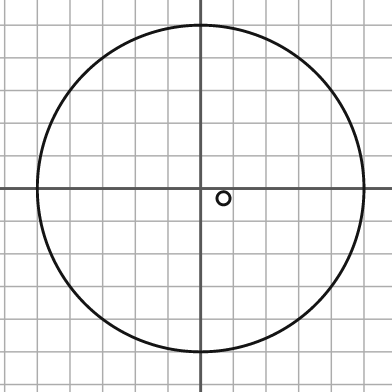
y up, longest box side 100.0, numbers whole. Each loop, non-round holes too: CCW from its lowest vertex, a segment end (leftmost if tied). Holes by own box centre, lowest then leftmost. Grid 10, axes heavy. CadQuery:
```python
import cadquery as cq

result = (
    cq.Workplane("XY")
    .moveTo(0.0, 0.0)
    .circle(50.0)
    .moveTo(7.0, -3.0)
    .circle(2.0)
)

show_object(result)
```